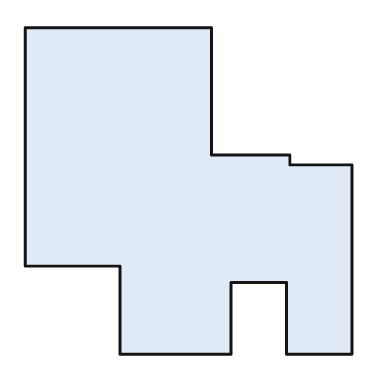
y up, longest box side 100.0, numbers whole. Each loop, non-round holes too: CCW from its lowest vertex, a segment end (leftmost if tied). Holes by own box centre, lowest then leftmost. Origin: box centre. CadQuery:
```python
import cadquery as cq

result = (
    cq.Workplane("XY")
    .moveTo(-21.0, -50.0)
    .lineTo(13.0, -50.0)
    .lineTo(13.0, -28.0)
    .lineTo(30.0, -28.0)
    .lineTo(30.0, -50.0)
    .lineTo(50.0, -50.0)
    .lineTo(50.0, 8.0)
    .lineTo(31.0, 8.0)
    .lineTo(31.0, 11.0)
    .lineTo(7.0, 11.0)
    .lineTo(7.0, 50.0)
    .lineTo(-50.0, 50.0)
    .lineTo(-50.0, -23.0)
    .lineTo(-21.0, -23.0)
    .close()
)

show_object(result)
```